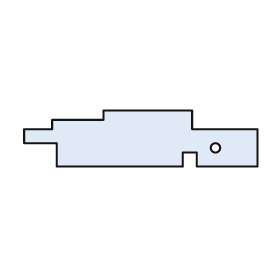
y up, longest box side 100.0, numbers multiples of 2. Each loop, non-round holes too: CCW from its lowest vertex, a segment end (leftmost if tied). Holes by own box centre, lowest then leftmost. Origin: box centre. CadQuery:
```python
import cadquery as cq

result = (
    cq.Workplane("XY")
    .moveTo(-36.0, -12.0)
    .lineTo(18.0, -12.0)
    .lineTo(18.0, -6.0)
    .lineTo(24.0, -6.0)
    .lineTo(24.0, -12.0)
    .lineTo(50.0, -12.0)
    .lineTo(50.0, 4.0)
    .lineTo(22.0, 4.0)
    .lineTo(22.0, 12.0)
    .lineTo(-16.0, 12.0)
    .lineTo(-16.0, 8.0)
    .lineTo(-38.0, 8.0)
    .lineTo(-38.0, 4.0)
    .lineTo(-50.0, 4.0)
    .lineTo(-50.0, -2.0)
    .lineTo(-36.0, -2.0)
    .close()
    .moveTo(32.0, -4.0)
    .circle(2.0)
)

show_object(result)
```